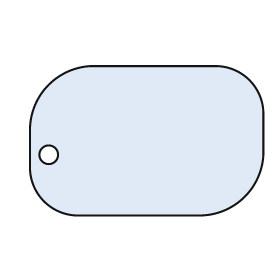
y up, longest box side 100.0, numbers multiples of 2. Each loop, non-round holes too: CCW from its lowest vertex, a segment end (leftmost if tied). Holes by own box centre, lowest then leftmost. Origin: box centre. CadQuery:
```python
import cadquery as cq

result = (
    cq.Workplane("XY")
    .moveTo(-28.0, -32.0)
    .lineTo(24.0, -32.0)
    .threePointArc((42.0, -24.0), (50.0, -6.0))
    .lineTo(50.0, 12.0)
    .threePointArc((44.0, 26.0), (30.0, 32.0))
    .lineTo(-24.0, 32.0)
    .threePointArc((-42.0, 24.0), (-50.0, 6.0))
    .lineTo(-50.0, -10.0)
    .threePointArc((-44.0, -26.0), (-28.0, -32.0))
    .close()
    .moveTo(-42.0, -6.0)
    .circle(4.0)
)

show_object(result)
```